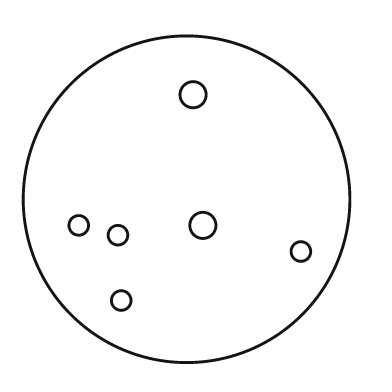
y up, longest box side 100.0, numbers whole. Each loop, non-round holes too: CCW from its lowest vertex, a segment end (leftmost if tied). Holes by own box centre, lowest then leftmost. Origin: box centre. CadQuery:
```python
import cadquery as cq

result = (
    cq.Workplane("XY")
    .moveTo(0.0, 0.0)
    .circle(50.0)
    .moveTo(-20.0, -31.0)
    .circle(3.0)
    .moveTo(35.0, -16.0)
    .circle(3.0)
    .moveTo(-21.0, -11.0)
    .circle(3.0)
    .moveTo(-33.0, -8.0)
    .circle(3.0)
    .moveTo(5.0, -8.0)
    .circle(4.0)
    .moveTo(2.0, 32.0)
    .circle(4.0)
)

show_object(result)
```